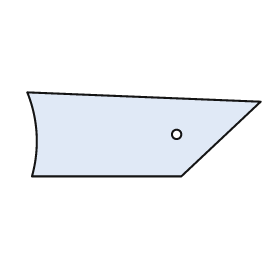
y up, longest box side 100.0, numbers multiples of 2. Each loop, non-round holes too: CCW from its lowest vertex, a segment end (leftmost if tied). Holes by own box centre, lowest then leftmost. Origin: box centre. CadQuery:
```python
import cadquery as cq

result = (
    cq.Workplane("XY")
    .moveTo(-48.0, -18.0)
    .lineTo(16.0, -18.0)
    .lineTo(50.0, 14.0)
    .lineTo(-50.0, 18.0)
    .threePointArc((-46.0, 0.0), (-48.0, -18.0))
    .close()
    .moveTo(14.0, 0.0)
    .circle(2.0)
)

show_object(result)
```